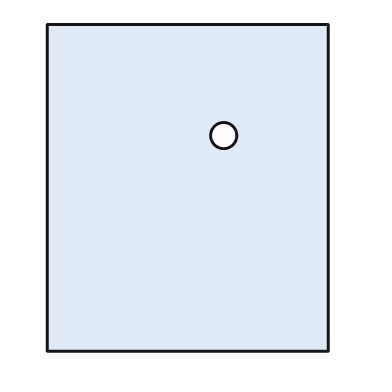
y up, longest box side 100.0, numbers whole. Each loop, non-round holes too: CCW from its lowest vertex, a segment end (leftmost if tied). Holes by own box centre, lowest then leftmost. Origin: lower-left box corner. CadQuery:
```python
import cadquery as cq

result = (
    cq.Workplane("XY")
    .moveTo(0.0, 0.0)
    .lineTo(86.0, 0.0)
    .lineTo(86.0, 100.0)
    .lineTo(0.0, 100.0)
    .close()
    .moveTo(54.0, 66.0)
    .circle(4.0)
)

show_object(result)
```